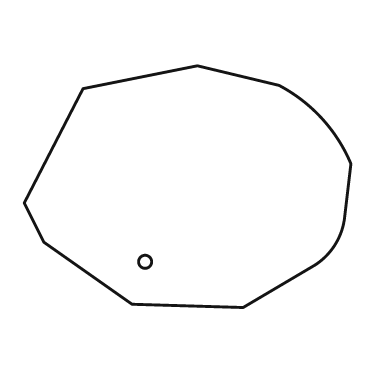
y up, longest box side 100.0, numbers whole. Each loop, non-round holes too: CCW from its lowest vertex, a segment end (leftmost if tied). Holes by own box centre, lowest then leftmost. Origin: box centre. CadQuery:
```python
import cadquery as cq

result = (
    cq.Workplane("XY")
    .moveTo(17.0, -37.0)
    .lineTo(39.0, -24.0)
    .threePointArc((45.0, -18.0), (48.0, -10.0))
    .lineTo(50.0, 7.0)
    .threePointArc((41.0, 21.0), (28.0, 31.0))
    .lineTo(3.0, 37.0)
    .lineTo(-32.0, 30.0)
    .lineTo(-50.0, -5.0)
    .lineTo(-44.0, -17.0)
    .lineTo(-17.0, -36.0)
    .close()
    .moveTo(-13.0, -23.0)
    .circle(2.0)
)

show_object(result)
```